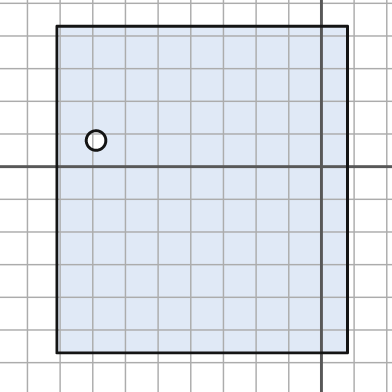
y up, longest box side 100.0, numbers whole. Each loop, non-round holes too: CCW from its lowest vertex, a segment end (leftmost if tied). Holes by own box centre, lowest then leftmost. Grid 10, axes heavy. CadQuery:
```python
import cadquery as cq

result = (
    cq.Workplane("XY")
    .moveTo(-81.0, -57.0)
    .lineTo(8.0, -57.0)
    .lineTo(8.0, 43.0)
    .lineTo(-81.0, 43.0)
    .close()
    .moveTo(-69.0, 8.0)
    .circle(3.0)
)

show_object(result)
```